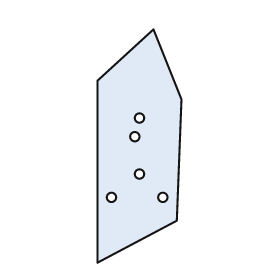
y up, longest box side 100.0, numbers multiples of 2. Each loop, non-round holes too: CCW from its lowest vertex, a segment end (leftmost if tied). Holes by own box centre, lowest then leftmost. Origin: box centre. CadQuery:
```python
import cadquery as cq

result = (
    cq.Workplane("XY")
    .moveTo(-18.0, -50.0)
    .lineTo(16.0, -32.0)
    .lineTo(18.0, 20.0)
    .lineTo(6.0, 50.0)
    .lineTo(-18.0, 28.0)
    .close()
    .moveTo(-12.0, -22.0)
    .circle(2.0)
    .moveTo(10.0, -22.0)
    .circle(2.0)
    .moveTo(0.0, -12.0)
    .circle(2.0)
    .moveTo(-2.0, 4.0)
    .circle(2.0)
    .moveTo(0.0, 12.0)
    .circle(2.0)
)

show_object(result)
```